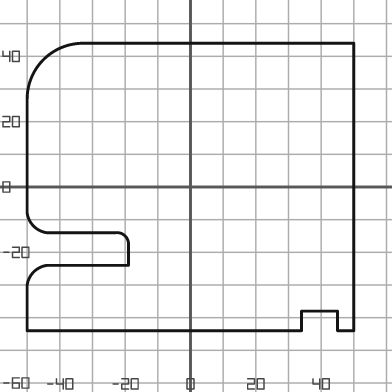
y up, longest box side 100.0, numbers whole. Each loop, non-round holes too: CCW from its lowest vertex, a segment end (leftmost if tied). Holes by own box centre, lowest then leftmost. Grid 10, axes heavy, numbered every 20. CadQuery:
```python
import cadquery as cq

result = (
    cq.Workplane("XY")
    .moveTo(-50.0, -44.0)
    .lineTo(34.0, -44.0)
    .lineTo(34.0, -38.0)
    .lineTo(45.0, -38.0)
    .lineTo(45.0, -44.0)
    .lineTo(50.0, -44.0)
    .lineTo(50.0, 44.0)
    .lineTo(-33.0, 44.0)
    .threePointArc((-45.0, 39.0), (-50.0, 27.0))
    .lineTo(-50.0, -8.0)
    .threePointArc((-48.0, -12.0), (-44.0, -14.0))
    .lineTo(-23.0, -14.0)
    .threePointArc((-20.0, -15.0), (-19.0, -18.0))
    .lineTo(-19.0, -24.0)
    .lineTo(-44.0, -24.0)
    .threePointArc((-48.0, -26.0), (-50.0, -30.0))
    .close()
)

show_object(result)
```